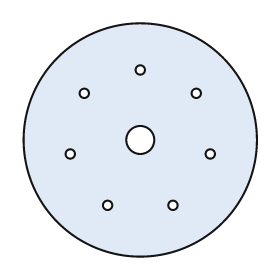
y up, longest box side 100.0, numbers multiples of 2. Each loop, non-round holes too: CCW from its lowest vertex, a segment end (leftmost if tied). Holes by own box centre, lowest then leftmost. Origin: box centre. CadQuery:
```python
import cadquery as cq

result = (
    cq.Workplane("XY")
    .moveTo(0.0, 0.0)
    .circle(50.0)
    .moveTo(-14.0, -28.0)
    .circle(2.0)
    .moveTo(14.0, -28.0)
    .circle(2.0)
    .moveTo(-30.0, -6.0)
    .circle(2.0)
    .moveTo(30.0, -6.0)
    .circle(2.0)
    .moveTo(0.0, 0.0)
    .circle(6.0)
    .moveTo(-24.0, 20.0)
    .circle(2.0)
    .moveTo(24.0, 20.0)
    .circle(2.0)
    .moveTo(0.0, 30.0)
    .circle(2.0)
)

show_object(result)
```